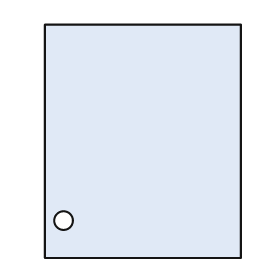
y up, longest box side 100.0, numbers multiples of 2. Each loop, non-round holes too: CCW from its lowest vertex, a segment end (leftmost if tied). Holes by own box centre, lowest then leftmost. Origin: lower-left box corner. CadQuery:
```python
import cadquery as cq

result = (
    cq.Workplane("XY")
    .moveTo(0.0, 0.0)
    .lineTo(84.0, 0.0)
    .lineTo(84.0, 100.0)
    .lineTo(0.0, 100.0)
    .close()
    .moveTo(8.0, 16.0)
    .circle(4.0)
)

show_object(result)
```